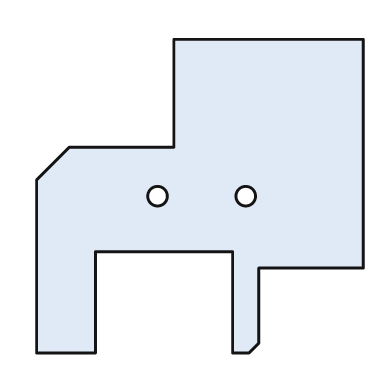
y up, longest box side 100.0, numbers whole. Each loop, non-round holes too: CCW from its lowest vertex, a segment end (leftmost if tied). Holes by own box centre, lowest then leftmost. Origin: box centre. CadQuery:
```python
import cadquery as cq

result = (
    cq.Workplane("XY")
    .moveTo(-50.0, -48.0)
    .lineTo(-32.0, -48.0)
    .lineTo(-32.0, -17.0)
    .lineTo(10.0, -17.0)
    .lineTo(10.0, -48.0)
    .lineTo(15.0, -48.0)
    .lineTo(18.0, -45.0)
    .lineTo(18.0, -22.0)
    .lineTo(50.0, -22.0)
    .lineTo(50.0, 48.0)
    .lineTo(-8.0, 48.0)
    .lineTo(-8.0, 15.0)
    .lineTo(-40.0, 15.0)
    .lineTo(-50.0, 5.0)
    .close()
    .moveTo(-13.0, 0.0)
    .circle(3.0)
    .moveTo(14.0, 0.0)
    .circle(3.0)
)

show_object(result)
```